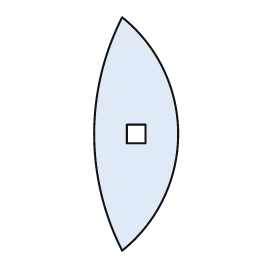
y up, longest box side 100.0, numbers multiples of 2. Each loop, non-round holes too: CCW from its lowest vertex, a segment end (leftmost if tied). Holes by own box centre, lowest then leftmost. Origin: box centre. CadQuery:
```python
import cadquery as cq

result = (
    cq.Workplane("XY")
    .moveTo(-6.0, -50.0)
    .threePointArc((18.0, 0.0), (-6.0, 50.0))
    .threePointArc((-18.0, 0.0), (-6.0, -50.0))
    .close()
    .moveTo(-4.0, -4.0)
    .lineTo(4.0, -4.0)
    .lineTo(4.0, 4.0)
    .lineTo(-4.0, 4.0)
    .close()
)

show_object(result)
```